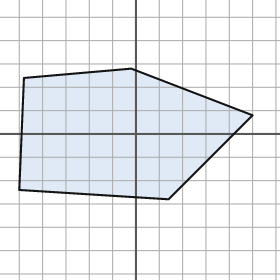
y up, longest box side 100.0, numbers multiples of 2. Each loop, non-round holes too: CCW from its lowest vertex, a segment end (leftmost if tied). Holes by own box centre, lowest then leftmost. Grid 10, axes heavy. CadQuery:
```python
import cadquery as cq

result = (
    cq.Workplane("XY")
    .moveTo(14.0, -28.0)
    .lineTo(50.0, 8.0)
    .lineTo(-2.0, 28.0)
    .lineTo(-48.0, 24.0)
    .lineTo(-50.0, -24.0)
    .close()
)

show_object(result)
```